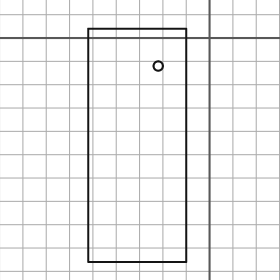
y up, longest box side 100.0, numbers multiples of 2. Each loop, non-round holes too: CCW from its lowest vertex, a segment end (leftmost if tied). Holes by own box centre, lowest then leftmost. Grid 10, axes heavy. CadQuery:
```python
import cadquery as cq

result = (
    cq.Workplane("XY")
    .moveTo(-52.0, -96.0)
    .lineTo(-10.0, -96.0)
    .lineTo(-10.0, 4.0)
    .lineTo(-52.0, 4.0)
    .close()
    .moveTo(-22.0, -12.0)
    .circle(2.0)
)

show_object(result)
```